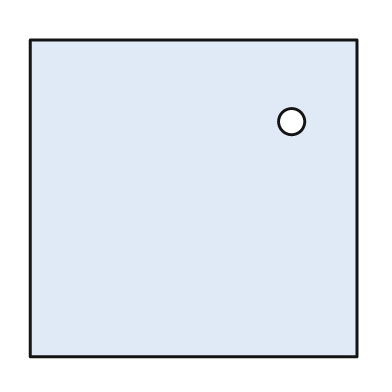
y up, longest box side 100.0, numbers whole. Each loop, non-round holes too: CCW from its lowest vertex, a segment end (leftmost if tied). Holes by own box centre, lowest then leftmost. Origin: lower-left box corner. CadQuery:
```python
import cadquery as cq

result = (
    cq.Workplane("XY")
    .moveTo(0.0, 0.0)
    .lineTo(100.0, 0.0)
    .lineTo(100.0, 97.0)
    .lineTo(0.0, 97.0)
    .close()
    .moveTo(80.0, 72.0)
    .circle(4.0)
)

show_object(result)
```